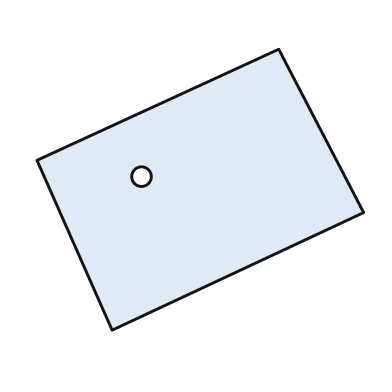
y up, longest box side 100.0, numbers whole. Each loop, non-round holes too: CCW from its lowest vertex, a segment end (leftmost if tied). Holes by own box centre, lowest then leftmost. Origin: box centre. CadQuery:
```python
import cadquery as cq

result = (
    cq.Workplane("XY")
    .moveTo(-27.0, -43.0)
    .lineTo(50.0, -7.0)
    .lineTo(24.0, 43.0)
    .lineTo(-50.0, 9.0)
    .close()
    .moveTo(-18.0, 4.0)
    .circle(3.0)
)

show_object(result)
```